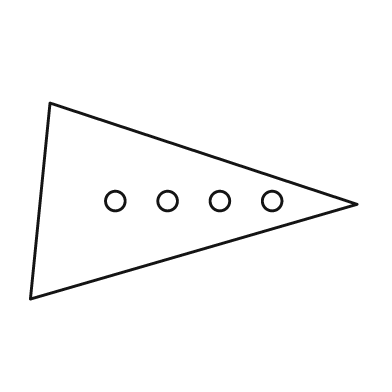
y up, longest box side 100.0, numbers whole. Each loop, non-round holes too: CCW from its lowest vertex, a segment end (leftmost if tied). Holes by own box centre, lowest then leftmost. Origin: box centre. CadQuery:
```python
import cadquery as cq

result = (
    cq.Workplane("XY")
    .moveTo(-50.0, -30.0)
    .lineTo(50.0, -1.0)
    .lineTo(-44.0, 30.0)
    .close()
    .moveTo(-24.0, 0.0)
    .circle(3.0)
    .moveTo(-8.0, 0.0)
    .circle(3.0)
    .moveTo(8.0, 0.0)
    .circle(3.0)
    .moveTo(24.0, 0.0)
    .circle(3.0)
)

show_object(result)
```